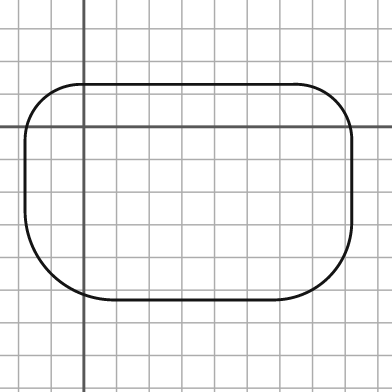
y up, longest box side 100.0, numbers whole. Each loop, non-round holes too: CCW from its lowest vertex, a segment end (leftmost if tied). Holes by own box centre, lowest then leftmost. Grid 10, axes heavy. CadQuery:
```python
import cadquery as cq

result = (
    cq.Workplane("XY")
    .moveTo(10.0, -53.0)
    .lineTo(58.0, -53.0)
    .threePointArc((75.0, -46.0), (82.0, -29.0))
    .lineTo(82.0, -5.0)
    .threePointArc((77.0, 8.0), (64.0, 13.0))
    .lineTo(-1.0, 13.0)
    .threePointArc((-13.0, 8.0), (-18.0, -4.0))
    .lineTo(-18.0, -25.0)
    .threePointArc((-10.0, -45.0), (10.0, -53.0))
    .close()
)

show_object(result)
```